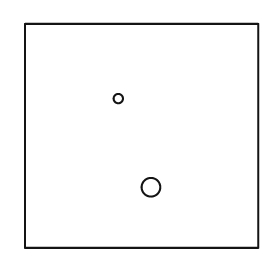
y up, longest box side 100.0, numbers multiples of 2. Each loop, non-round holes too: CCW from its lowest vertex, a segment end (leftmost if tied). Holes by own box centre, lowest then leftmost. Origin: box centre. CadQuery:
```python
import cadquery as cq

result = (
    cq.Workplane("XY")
    .moveTo(-50.0, -48.0)
    .lineTo(50.0, -48.0)
    .lineTo(50.0, 48.0)
    .lineTo(-50.0, 48.0)
    .close()
    .moveTo(4.0, -22.0)
    .circle(4.0)
    .moveTo(-10.0, 16.0)
    .circle(2.0)
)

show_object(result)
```